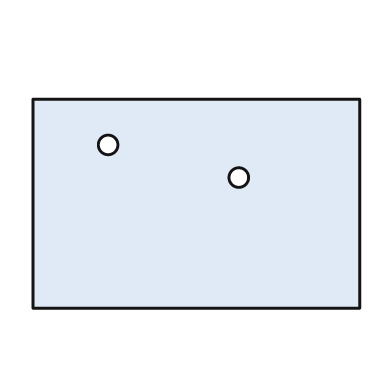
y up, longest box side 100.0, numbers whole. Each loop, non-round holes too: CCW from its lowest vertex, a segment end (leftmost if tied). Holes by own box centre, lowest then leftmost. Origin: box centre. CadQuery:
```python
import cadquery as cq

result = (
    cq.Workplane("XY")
    .moveTo(-50.0, -32.0)
    .lineTo(50.0, -32.0)
    .lineTo(50.0, 32.0)
    .lineTo(-50.0, 32.0)
    .close()
    .moveTo(13.0, 8.0)
    .circle(3.0)
    .moveTo(-27.0, 18.0)
    .circle(3.0)
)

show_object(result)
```